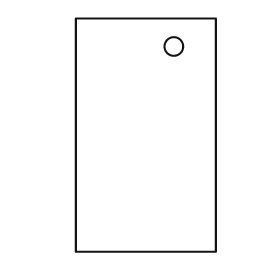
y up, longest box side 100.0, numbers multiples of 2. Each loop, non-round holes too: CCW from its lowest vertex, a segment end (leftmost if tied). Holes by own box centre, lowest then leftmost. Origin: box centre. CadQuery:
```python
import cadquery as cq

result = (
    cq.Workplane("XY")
    .moveTo(-30.0, -50.0)
    .lineTo(30.0, -50.0)
    .lineTo(30.0, 50.0)
    .lineTo(-30.0, 50.0)
    .close()
    .moveTo(12.0, 38.0)
    .circle(4.0)
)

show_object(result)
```